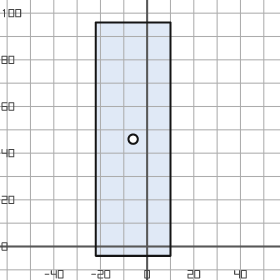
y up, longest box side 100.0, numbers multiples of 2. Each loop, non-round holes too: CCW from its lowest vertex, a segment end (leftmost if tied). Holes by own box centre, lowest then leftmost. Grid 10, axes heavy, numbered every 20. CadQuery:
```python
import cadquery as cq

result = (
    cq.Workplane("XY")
    .moveTo(-22.0, -4.0)
    .lineTo(10.0, -4.0)
    .lineTo(10.0, 96.0)
    .lineTo(-22.0, 96.0)
    .close()
    .moveTo(-6.0, 46.0)
    .circle(2.0)
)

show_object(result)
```